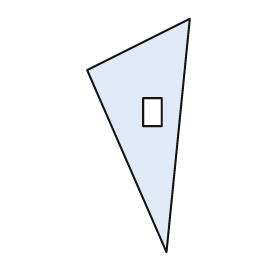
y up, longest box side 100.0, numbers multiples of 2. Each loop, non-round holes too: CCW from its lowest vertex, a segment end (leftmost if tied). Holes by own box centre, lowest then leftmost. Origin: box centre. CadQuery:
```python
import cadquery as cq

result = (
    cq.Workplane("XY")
    .moveTo(12.0, -50.0)
    .lineTo(22.0, 50.0)
    .lineTo(-22.0, 28.0)
    .close()
    .moveTo(2.0, 4.0)
    .lineTo(10.0, 4.0)
    .lineTo(10.0, 16.0)
    .lineTo(2.0, 16.0)
    .close()
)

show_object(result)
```